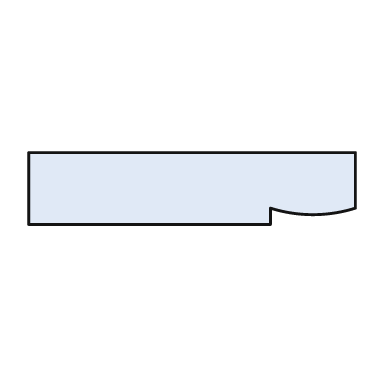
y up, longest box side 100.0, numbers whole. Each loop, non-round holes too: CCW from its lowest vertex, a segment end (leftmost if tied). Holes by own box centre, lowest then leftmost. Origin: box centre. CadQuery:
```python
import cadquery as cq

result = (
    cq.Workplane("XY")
    .moveTo(-50.0, -11.0)
    .lineTo(24.0, -11.0)
    .lineTo(24.0, -6.0)
    .threePointArc((37.0, -8.0), (50.0, -6.0))
    .lineTo(50.0, 11.0)
    .lineTo(-50.0, 11.0)
    .close()
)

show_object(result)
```